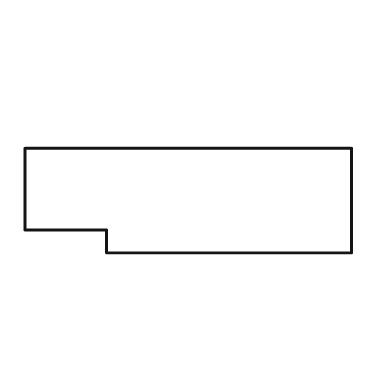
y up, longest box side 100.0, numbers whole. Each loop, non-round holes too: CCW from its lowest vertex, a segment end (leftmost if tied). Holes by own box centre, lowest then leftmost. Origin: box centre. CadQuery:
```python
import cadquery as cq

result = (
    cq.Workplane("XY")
    .moveTo(-25.0, -16.0)
    .lineTo(50.0, -16.0)
    .lineTo(50.0, 16.0)
    .lineTo(-50.0, 16.0)
    .lineTo(-50.0, -9.0)
    .lineTo(-25.0, -9.0)
    .close()
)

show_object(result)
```